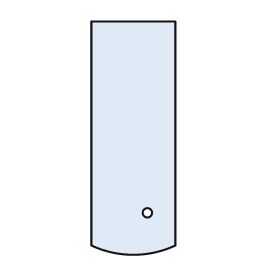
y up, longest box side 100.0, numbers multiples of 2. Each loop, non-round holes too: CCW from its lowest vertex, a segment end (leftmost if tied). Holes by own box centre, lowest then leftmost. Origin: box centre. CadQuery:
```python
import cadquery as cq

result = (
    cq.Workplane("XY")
    .moveTo(-18.0, -46.0)
    .threePointArc((0.0, -50.0), (18.0, -46.0))
    .lineTo(18.0, 50.0)
    .lineTo(-18.0, 50.0)
    .close()
    .moveTo(6.0, -32.0)
    .circle(2.0)
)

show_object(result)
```